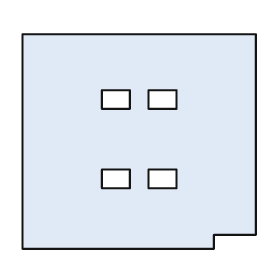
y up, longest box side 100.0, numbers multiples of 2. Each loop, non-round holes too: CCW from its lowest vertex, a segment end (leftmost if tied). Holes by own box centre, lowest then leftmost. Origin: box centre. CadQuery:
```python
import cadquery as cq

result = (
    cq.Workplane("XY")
    .moveTo(-50.0, -46.0)
    .lineTo(32.0, -46.0)
    .lineTo(32.0, -40.0)
    .lineTo(50.0, -40.0)
    .lineTo(50.0, 46.0)
    .lineTo(-50.0, 46.0)
    .close()
    .moveTo(-16.0, -20.0)
    .lineTo(-4.0, -20.0)
    .lineTo(-4.0, -12.0)
    .lineTo(-16.0, -12.0)
    .close()
    .moveTo(4.0, -20.0)
    .lineTo(16.0, -20.0)
    .lineTo(16.0, -12.0)
    .lineTo(4.0, -12.0)
    .close()
    .moveTo(-16.0, 14.0)
    .lineTo(-4.0, 14.0)
    .lineTo(-4.0, 22.0)
    .lineTo(-16.0, 22.0)
    .close()
    .moveTo(4.0, 14.0)
    .lineTo(16.0, 14.0)
    .lineTo(16.0, 22.0)
    .lineTo(4.0, 22.0)
    .close()
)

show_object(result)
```